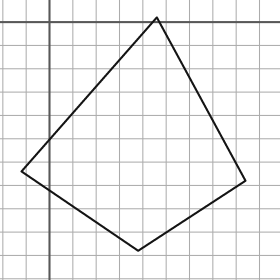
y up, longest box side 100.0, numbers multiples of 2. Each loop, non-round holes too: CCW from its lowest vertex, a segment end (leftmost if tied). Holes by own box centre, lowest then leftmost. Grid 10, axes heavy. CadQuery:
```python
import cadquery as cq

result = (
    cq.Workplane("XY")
    .moveTo(38.0, -98.0)
    .lineTo(84.0, -68.0)
    .lineTo(46.0, 2.0)
    .lineTo(-12.0, -64.0)
    .close()
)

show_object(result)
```